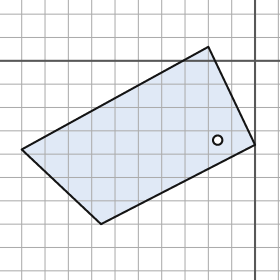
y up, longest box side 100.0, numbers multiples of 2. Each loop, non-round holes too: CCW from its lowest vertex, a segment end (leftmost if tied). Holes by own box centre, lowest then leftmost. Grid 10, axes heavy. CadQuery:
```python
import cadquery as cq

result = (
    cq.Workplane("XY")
    .moveTo(-66.0, -70.0)
    .lineTo(0.0, -36.0)
    .lineTo(-20.0, 6.0)
    .lineTo(-100.0, -38.0)
    .close()
    .moveTo(-16.0, -34.0)
    .circle(2.0)
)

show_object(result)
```